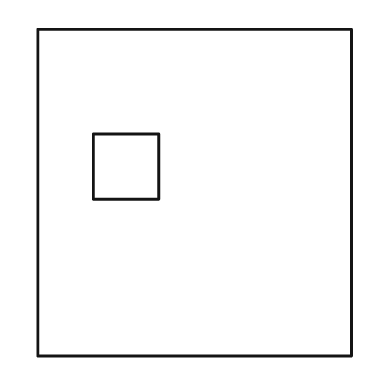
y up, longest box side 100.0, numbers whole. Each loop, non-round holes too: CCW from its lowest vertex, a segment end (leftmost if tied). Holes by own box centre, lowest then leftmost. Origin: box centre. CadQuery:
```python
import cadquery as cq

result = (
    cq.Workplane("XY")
    .moveTo(-48.0, -50.0)
    .lineTo(48.0, -50.0)
    .lineTo(48.0, 50.0)
    .lineTo(-48.0, 50.0)
    .close()
    .moveTo(-31.0, -2.0)
    .lineTo(-11.0, -2.0)
    .lineTo(-11.0, 18.0)
    .lineTo(-31.0, 18.0)
    .close()
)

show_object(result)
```